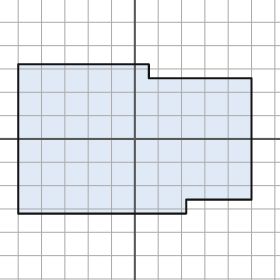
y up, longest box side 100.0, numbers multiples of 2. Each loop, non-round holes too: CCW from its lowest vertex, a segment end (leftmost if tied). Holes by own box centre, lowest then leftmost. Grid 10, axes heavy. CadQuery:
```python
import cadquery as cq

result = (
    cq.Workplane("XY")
    .moveTo(-50.0, -32.0)
    .lineTo(22.0, -32.0)
    .lineTo(22.0, -26.0)
    .lineTo(50.0, -26.0)
    .lineTo(50.0, 26.0)
    .lineTo(6.0, 26.0)
    .lineTo(6.0, 32.0)
    .lineTo(-50.0, 32.0)
    .close()
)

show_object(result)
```